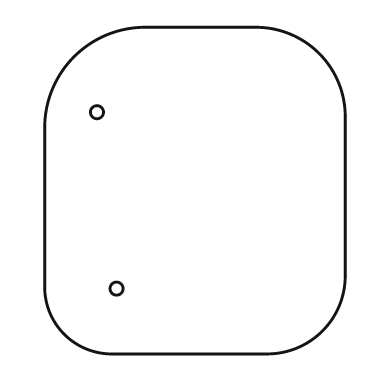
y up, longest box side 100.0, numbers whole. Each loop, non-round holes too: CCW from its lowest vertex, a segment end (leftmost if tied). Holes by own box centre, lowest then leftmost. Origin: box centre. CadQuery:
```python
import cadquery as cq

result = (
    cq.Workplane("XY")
    .moveTo(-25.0, -50.0)
    .lineTo(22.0, -50.0)
    .threePointArc((39.0, -43.0), (46.0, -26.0))
    .lineTo(46.0, 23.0)
    .threePointArc((38.0, 42.0), (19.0, 50.0))
    .lineTo(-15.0, 50.0)
    .threePointArc((-37.0, 41.0), (-46.0, 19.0))
    .lineTo(-46.0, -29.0)
    .threePointArc((-40.0, -44.0), (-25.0, -50.0))
    .close()
    .moveTo(-24.0, -30.0)
    .circle(2.0)
    .moveTo(-30.0, 24.0)
    .circle(2.0)
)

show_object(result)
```